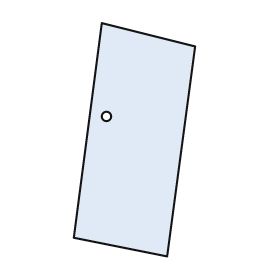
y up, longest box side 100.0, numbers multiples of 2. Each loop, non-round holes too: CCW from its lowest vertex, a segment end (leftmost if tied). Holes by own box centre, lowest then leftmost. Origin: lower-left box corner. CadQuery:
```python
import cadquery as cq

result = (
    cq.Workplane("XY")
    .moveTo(40.0, 0.0)
    .lineTo(52.0, 90.0)
    .lineTo(12.0, 100.0)
    .lineTo(0.0, 8.0)
    .close()
    .moveTo(14.0, 60.0)
    .circle(2.0)
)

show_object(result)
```